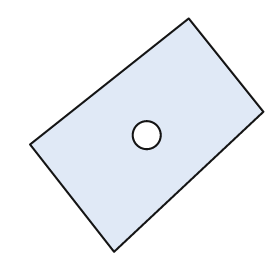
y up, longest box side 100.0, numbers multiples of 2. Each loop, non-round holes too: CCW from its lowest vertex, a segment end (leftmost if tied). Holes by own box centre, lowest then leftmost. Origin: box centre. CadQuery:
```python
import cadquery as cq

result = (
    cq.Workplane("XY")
    .moveTo(-14.0, -50.0)
    .lineTo(50.0, 10.0)
    .lineTo(18.0, 50.0)
    .lineTo(-50.0, -4.0)
    .close()
    .moveTo(0.0, 0.0)
    .circle(6.0)
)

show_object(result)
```